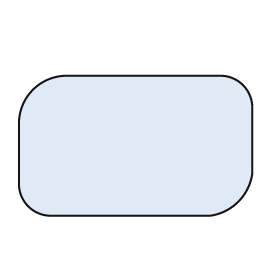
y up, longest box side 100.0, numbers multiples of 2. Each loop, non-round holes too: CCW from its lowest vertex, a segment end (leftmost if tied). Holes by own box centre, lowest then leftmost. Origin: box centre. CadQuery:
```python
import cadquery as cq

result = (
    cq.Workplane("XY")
    .moveTo(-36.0, -30.0)
    .lineTo(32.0, -30.0)
    .threePointArc((44.0, -24.0), (50.0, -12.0))
    .lineTo(50.0, 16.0)
    .threePointArc((46.0, 26.0), (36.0, 30.0))
    .lineTo(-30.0, 30.0)
    .threePointArc((-44.0, 24.0), (-50.0, 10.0))
    .lineTo(-50.0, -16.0)
    .threePointArc((-46.0, -26.0), (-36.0, -30.0))
    .close()
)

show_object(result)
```